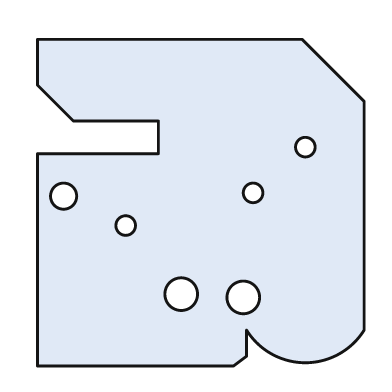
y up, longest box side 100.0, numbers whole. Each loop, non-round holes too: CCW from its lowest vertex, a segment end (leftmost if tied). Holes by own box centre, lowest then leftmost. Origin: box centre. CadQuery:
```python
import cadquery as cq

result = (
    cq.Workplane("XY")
    .moveTo(-50.0, -50.0)
    .lineTo(10.0, -50.0)
    .lineTo(14.0, -47.0)
    .lineTo(14.0, -39.0)
    .threePointArc((32.0, -49.0), (50.0, -39.0))
    .lineTo(50.0, 31.0)
    .lineTo(31.0, 50.0)
    .lineTo(-50.0, 50.0)
    .lineTo(-50.0, 36.0)
    .lineTo(-39.0, 25.0)
    .lineTo(-13.0, 25.0)
    .lineTo(-13.0, 15.0)
    .lineTo(-50.0, 15.0)
    .close()
    .moveTo(13.0, -29.0)
    .circle(5.0)
    .moveTo(-6.0, -28.0)
    .circle(5.0)
    .moveTo(-23.0, -7.0)
    .circle(3.0)
    .moveTo(-42.0, 2.0)
    .circle(4.0)
    .moveTo(16.0, 3.0)
    .circle(3.0)
    .moveTo(32.0, 17.0)
    .circle(3.0)
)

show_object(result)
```